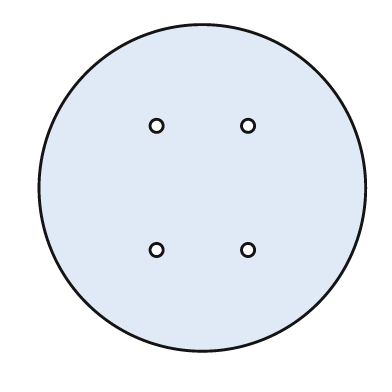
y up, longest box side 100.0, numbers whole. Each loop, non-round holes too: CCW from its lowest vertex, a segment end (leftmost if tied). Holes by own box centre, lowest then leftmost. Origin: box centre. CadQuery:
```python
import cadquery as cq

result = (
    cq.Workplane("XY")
    .moveTo(0.0, 0.0)
    .circle(50.0)
    .moveTo(-14.0, -19.0)
    .circle(2.0)
    .moveTo(14.0, -19.0)
    .circle(2.0)
    .moveTo(-14.0, 19.0)
    .circle(2.0)
    .moveTo(14.0, 19.0)
    .circle(2.0)
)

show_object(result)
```